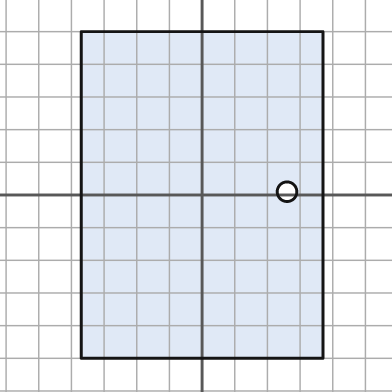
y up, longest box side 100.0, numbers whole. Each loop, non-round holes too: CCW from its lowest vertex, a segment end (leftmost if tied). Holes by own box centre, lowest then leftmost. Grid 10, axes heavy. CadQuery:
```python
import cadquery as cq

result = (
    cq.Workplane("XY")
    .moveTo(-37.0, -50.0)
    .lineTo(37.0, -50.0)
    .lineTo(37.0, 50.0)
    .lineTo(-37.0, 50.0)
    .close()
    .moveTo(26.0, 1.0)
    .circle(3.0)
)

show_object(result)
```